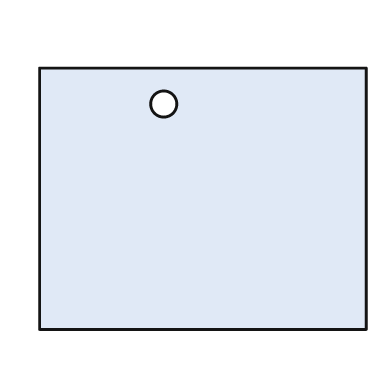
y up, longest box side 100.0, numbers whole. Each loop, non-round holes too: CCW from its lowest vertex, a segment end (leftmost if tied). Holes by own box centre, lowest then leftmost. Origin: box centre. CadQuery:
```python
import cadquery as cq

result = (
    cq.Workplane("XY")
    .moveTo(-50.0, -40.0)
    .lineTo(50.0, -40.0)
    .lineTo(50.0, 40.0)
    .lineTo(-50.0, 40.0)
    .close()
    .moveTo(-12.0, 29.0)
    .circle(4.0)
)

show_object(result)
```